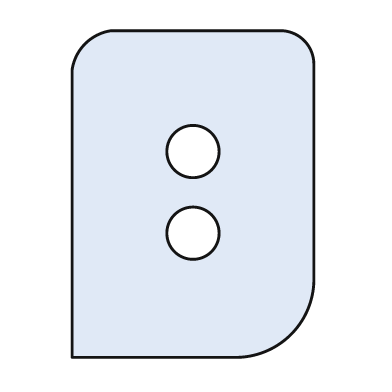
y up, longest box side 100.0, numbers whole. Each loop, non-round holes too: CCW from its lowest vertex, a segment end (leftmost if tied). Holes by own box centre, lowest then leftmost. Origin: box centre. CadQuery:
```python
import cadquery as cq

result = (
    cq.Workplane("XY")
    .moveTo(-37.0, -50.0)
    .lineTo(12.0, -50.0)
    .threePointArc((30.0, -43.0), (37.0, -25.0))
    .lineTo(37.0, 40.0)
    .threePointArc((34.0, 47.0), (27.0, 50.0))
    .lineTo(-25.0, 50.0)
    .threePointArc((-33.0, 46.0), (-37.0, 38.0))
    .close()
    .moveTo(0.0, -12.0)
    .circle(8.0)
    .moveTo(0.0, 13.0)
    .circle(8.0)
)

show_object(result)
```